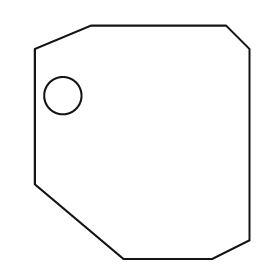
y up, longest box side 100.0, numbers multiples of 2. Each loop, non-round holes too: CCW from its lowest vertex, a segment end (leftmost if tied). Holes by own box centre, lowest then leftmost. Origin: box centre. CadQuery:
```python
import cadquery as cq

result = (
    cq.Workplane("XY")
    .moveTo(-8.0, -50.0)
    .lineTo(30.0, -50.0)
    .lineTo(46.0, -42.0)
    .lineTo(46.0, 40.0)
    .lineTo(36.0, 50.0)
    .lineTo(-22.0, 50.0)
    .lineTo(-46.0, 40.0)
    .lineTo(-46.0, -18.0)
    .close()
    .moveTo(-34.0, 20.0)
    .circle(8.0)
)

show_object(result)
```